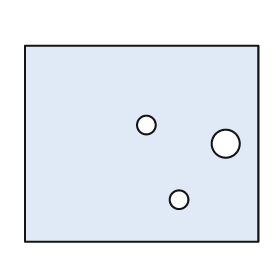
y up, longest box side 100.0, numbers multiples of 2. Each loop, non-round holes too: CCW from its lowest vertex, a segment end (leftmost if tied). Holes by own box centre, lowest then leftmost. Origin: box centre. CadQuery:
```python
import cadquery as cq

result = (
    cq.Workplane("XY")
    .moveTo(-50.0, -42.0)
    .lineTo(50.0, -42.0)
    .lineTo(50.0, 42.0)
    .lineTo(-50.0, 42.0)
    .close()
    .moveTo(16.0, -24.0)
    .circle(4.0)
    .moveTo(36.0, 0.0)
    .circle(6.0)
    .moveTo(2.0, 8.0)
    .circle(4.0)
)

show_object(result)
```